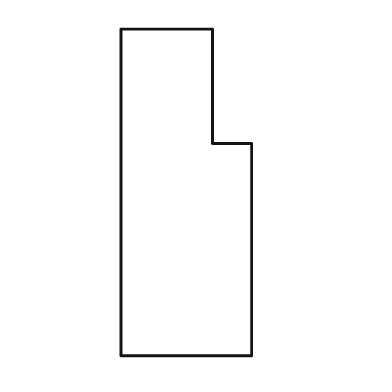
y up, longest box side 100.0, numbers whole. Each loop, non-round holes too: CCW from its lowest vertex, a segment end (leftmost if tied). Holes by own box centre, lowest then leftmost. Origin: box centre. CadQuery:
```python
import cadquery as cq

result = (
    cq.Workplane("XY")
    .moveTo(-20.0, -50.0)
    .lineTo(20.0, -50.0)
    .lineTo(20.0, 15.0)
    .lineTo(8.0, 15.0)
    .lineTo(8.0, 50.0)
    .lineTo(-20.0, 50.0)
    .close()
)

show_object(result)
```